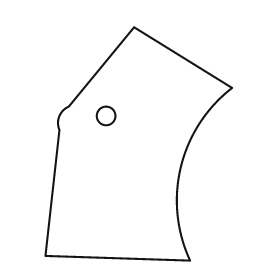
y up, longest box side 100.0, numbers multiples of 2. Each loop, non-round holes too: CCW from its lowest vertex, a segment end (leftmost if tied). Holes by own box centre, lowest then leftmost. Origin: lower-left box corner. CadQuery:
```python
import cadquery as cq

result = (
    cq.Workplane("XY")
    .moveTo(62.0, 0.0)
    .threePointArc((58.0, 40.0), (80.0, 74.0))
    .lineTo(38.0, 100.0)
    .lineTo(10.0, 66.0)
    .threePointArc((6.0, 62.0), (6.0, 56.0))
    .lineTo(0.0, 2.0)
    .close()
    .moveTo(26.0, 62.0)
    .circle(4.0)
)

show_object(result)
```